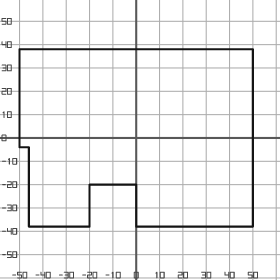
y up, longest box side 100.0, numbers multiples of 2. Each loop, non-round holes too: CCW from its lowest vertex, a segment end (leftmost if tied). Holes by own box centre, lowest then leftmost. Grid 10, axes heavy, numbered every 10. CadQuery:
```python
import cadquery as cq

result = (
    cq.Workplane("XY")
    .moveTo(-46.0, -38.0)
    .lineTo(-20.0, -38.0)
    .lineTo(-20.0, -20.0)
    .lineTo(0.0, -20.0)
    .lineTo(0.0, -38.0)
    .lineTo(50.0, -38.0)
    .lineTo(50.0, 38.0)
    .lineTo(-50.0, 38.0)
    .lineTo(-50.0, -4.0)
    .lineTo(-46.0, -4.0)
    .close()
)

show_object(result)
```